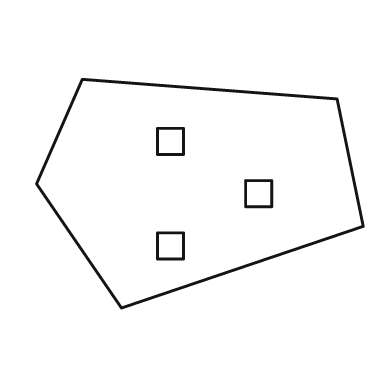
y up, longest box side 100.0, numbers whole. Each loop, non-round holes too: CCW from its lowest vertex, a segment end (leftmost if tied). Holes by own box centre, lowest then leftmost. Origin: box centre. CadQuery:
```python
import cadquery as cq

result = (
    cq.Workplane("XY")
    .moveTo(-24.0, -35.0)
    .lineTo(50.0, -10.0)
    .lineTo(42.0, 29.0)
    .lineTo(-36.0, 35.0)
    .lineTo(-50.0, 3.0)
    .close()
    .moveTo(-13.0, -20.0)
    .lineTo(-5.0, -20.0)
    .lineTo(-5.0, -12.0)
    .lineTo(-13.0, -12.0)
    .close()
    .moveTo(14.0, -4.0)
    .lineTo(22.0, -4.0)
    .lineTo(22.0, 4.0)
    .lineTo(14.0, 4.0)
    .close()
    .moveTo(-13.0, 12.0)
    .lineTo(-5.0, 12.0)
    .lineTo(-5.0, 20.0)
    .lineTo(-13.0, 20.0)
    .close()
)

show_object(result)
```